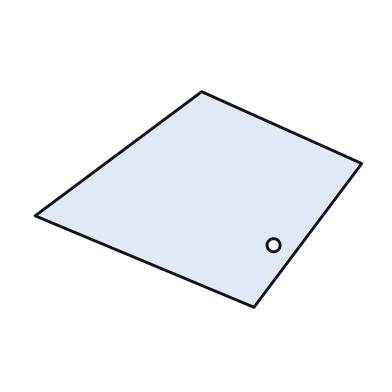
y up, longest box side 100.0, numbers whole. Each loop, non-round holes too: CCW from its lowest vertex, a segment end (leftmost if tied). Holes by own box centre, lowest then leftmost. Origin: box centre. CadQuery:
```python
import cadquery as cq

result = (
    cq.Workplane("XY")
    .moveTo(17.0, -33.0)
    .lineTo(50.0, 11.0)
    .lineTo(1.0, 33.0)
    .lineTo(-50.0, -5.0)
    .close()
    .moveTo(23.0, -14.0)
    .circle(2.0)
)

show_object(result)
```